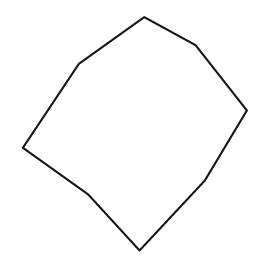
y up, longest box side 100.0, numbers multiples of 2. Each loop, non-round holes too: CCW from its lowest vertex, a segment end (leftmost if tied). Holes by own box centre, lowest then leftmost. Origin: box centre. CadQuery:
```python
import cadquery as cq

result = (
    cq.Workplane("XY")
    .moveTo(2.0, -50.0)
    .lineTo(30.0, -20.0)
    .lineTo(48.0, 10.0)
    .lineTo(26.0, 38.0)
    .lineTo(4.0, 50.0)
    .lineTo(-24.0, 30.0)
    .lineTo(-48.0, -6.0)
    .lineTo(-20.0, -26.0)
    .close()
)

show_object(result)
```